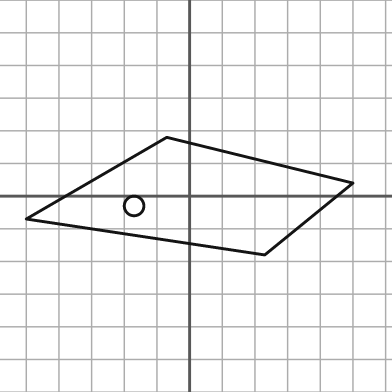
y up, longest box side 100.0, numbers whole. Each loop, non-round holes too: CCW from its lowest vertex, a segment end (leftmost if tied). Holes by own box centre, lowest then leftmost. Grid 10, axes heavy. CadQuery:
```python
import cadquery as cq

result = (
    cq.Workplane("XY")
    .moveTo(23.0, -18.0)
    .lineTo(50.0, 4.0)
    .lineTo(-7.0, 18.0)
    .lineTo(-50.0, -7.0)
    .close()
    .moveTo(-17.0, -3.0)
    .circle(3.0)
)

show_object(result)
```